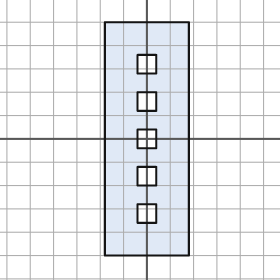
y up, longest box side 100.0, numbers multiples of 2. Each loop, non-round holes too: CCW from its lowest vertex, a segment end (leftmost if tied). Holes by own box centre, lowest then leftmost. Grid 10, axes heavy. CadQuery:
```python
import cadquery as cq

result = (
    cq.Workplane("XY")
    .moveTo(-18.0, -50.0)
    .lineTo(18.0, -50.0)
    .lineTo(18.0, 50.0)
    .lineTo(-18.0, 50.0)
    .close()
    .moveTo(-4.0, -36.0)
    .lineTo(4.0, -36.0)
    .lineTo(4.0, -28.0)
    .lineTo(-4.0, -28.0)
    .close()
    .moveTo(-4.0, -20.0)
    .lineTo(4.0, -20.0)
    .lineTo(4.0, -12.0)
    .lineTo(-4.0, -12.0)
    .close()
    .moveTo(-4.0, -4.0)
    .lineTo(4.0, -4.0)
    .lineTo(4.0, 4.0)
    .lineTo(-4.0, 4.0)
    .close()
    .moveTo(-4.0, 12.0)
    .lineTo(4.0, 12.0)
    .lineTo(4.0, 20.0)
    .lineTo(-4.0, 20.0)
    .close()
    .moveTo(-4.0, 28.0)
    .lineTo(4.0, 28.0)
    .lineTo(4.0, 36.0)
    .lineTo(-4.0, 36.0)
    .close()
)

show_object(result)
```